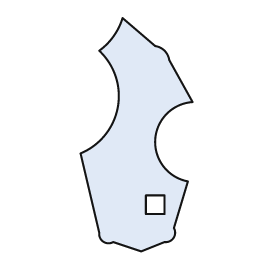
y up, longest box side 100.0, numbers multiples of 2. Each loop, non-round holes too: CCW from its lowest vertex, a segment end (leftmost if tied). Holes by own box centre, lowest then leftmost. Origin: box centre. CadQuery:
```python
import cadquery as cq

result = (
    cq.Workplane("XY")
    .moveTo(2.0, -50.0)
    .lineTo(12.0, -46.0)
    .threePointArc((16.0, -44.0), (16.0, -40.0))
    .lineTo(22.0, -20.0)
    .threePointArc((8.0, -2.0), (24.0, 14.0))
    .lineTo(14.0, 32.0)
    .threePointArc((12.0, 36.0), (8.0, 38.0))
    .lineTo(-6.0, 50.0)
    .threePointArc((-10.0, 42.0), (-16.0, 36.0))
    .threePointArc((-8.0, 12.0), (-24.0, -8.0))
    .lineTo(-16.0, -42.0)
    .threePointArc((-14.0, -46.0), (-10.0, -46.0))
    .close()
    .moveTo(4.0, -34.0)
    .lineTo(12.0, -34.0)
    .lineTo(12.0, -26.0)
    .lineTo(4.0, -26.0)
    .close()
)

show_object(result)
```